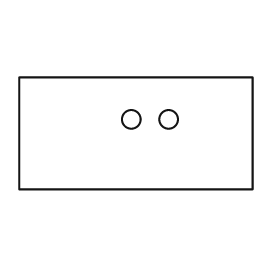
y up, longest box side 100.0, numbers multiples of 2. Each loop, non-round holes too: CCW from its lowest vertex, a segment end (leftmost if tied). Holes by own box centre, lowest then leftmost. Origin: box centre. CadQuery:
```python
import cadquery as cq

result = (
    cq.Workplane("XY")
    .moveTo(-50.0, -24.0)
    .lineTo(50.0, -24.0)
    .lineTo(50.0, 24.0)
    .lineTo(-50.0, 24.0)
    .close()
    .moveTo(-2.0, 6.0)
    .circle(4.0)
    .moveTo(14.0, 6.0)
    .circle(4.0)
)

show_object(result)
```